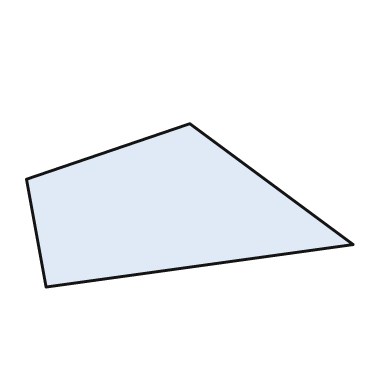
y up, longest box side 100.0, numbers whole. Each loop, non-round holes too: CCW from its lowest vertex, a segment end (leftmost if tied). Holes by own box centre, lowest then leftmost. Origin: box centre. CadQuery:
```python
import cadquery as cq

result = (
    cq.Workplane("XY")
    .moveTo(-44.0, -25.0)
    .lineTo(50.0, -12.0)
    .lineTo(0.0, 25.0)
    .lineTo(-50.0, 8.0)
    .close()
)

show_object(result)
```